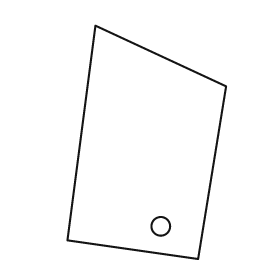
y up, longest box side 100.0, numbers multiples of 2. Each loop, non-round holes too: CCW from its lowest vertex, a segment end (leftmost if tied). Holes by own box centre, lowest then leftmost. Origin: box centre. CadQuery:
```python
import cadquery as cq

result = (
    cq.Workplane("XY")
    .moveTo(22.0, -50.0)
    .lineTo(34.0, 24.0)
    .lineTo(-22.0, 50.0)
    .lineTo(-34.0, -42.0)
    .close()
    .moveTo(6.0, -36.0)
    .circle(4.0)
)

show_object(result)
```